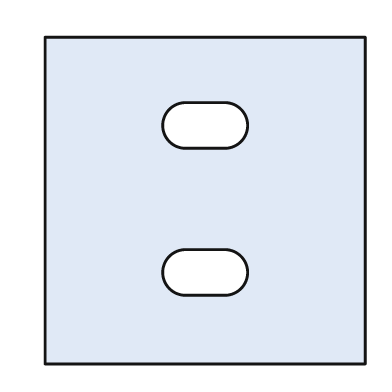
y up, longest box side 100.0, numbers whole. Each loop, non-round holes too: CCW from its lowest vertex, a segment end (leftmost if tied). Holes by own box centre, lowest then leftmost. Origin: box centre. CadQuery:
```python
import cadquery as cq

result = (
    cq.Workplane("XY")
    .moveTo(-49.0, -50.0)
    .lineTo(49.0, -50.0)
    .lineTo(49.0, 50.0)
    .lineTo(-49.0, 50.0)
    .close()
    .moveTo(-6.0, -29.0)
    .lineTo(6.0, -29.0)
    .threePointArc((13.0, -22.0), (6.0, -15.0))
    .lineTo(-6.0, -15.0)
    .threePointArc((-13.0, -22.0), (-6.0, -29.0))
    .close()
    .moveTo(-6.0, 16.0)
    .lineTo(6.0, 16.0)
    .threePointArc((13.0, 23.0), (6.0, 30.0))
    .lineTo(-6.0, 30.0)
    .threePointArc((-13.0, 23.0), (-6.0, 16.0))
    .close()
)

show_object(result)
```